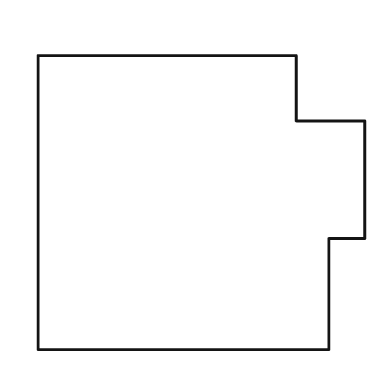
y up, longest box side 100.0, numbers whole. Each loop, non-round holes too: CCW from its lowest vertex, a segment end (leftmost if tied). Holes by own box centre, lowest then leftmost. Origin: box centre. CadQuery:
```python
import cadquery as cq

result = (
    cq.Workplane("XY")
    .moveTo(-50.0, -45.0)
    .lineTo(39.0, -45.0)
    .lineTo(39.0, -11.0)
    .lineTo(50.0, -11.0)
    .lineTo(50.0, 25.0)
    .lineTo(29.0, 25.0)
    .lineTo(29.0, 45.0)
    .lineTo(-50.0, 45.0)
    .close()
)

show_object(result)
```